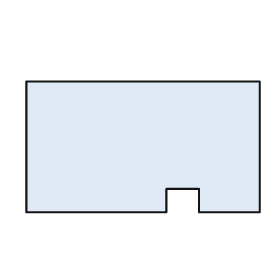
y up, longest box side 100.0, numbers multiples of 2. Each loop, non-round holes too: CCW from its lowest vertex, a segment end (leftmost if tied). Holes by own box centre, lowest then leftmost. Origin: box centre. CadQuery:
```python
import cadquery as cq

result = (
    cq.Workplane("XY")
    .moveTo(-50.0, -28.0)
    .lineTo(10.0, -28.0)
    .lineTo(10.0, -18.0)
    .lineTo(24.0, -18.0)
    .lineTo(24.0, -28.0)
    .lineTo(50.0, -28.0)
    .lineTo(50.0, 28.0)
    .lineTo(-50.0, 28.0)
    .close()
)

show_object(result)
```